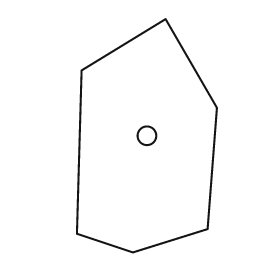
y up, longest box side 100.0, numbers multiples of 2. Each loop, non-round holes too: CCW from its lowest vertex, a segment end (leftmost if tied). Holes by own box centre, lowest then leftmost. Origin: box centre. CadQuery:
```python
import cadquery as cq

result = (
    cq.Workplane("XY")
    .moveTo(-6.0, -50.0)
    .lineTo(26.0, -40.0)
    .lineTo(30.0, 12.0)
    .lineTo(8.0, 50.0)
    .lineTo(-28.0, 28.0)
    .lineTo(-30.0, -42.0)
    .close()
    .moveTo(0.0, 0.0)
    .circle(4.0)
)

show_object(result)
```